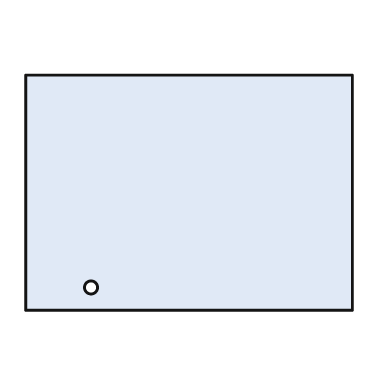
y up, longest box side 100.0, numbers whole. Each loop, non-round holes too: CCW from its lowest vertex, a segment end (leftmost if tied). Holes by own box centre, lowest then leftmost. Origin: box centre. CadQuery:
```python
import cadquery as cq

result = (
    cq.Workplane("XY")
    .moveTo(-50.0, -36.0)
    .lineTo(50.0, -36.0)
    .lineTo(50.0, 36.0)
    .lineTo(-50.0, 36.0)
    .close()
    .moveTo(-30.0, -29.0)
    .circle(2.0)
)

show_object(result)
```